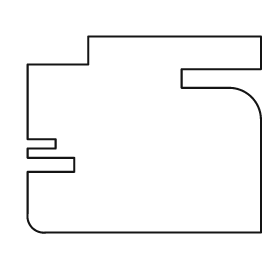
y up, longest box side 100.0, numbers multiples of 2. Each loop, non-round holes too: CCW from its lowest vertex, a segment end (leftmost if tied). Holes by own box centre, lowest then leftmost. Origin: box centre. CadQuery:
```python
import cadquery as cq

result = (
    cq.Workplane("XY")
    .moveTo(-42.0, -42.0)
    .lineTo(50.0, -42.0)
    .lineTo(50.0, 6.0)
    .threePointArc((46.0, 16.0), (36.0, 20.0))
    .lineTo(16.0, 20.0)
    .lineTo(16.0, 28.0)
    .lineTo(50.0, 28.0)
    .lineTo(50.0, 42.0)
    .lineTo(-24.0, 42.0)
    .lineTo(-24.0, 30.0)
    .lineTo(-50.0, 30.0)
    .lineTo(-50.0, -2.0)
    .lineTo(-38.0, -2.0)
    .lineTo(-38.0, -6.0)
    .lineTo(-50.0, -6.0)
    .lineTo(-50.0, -10.0)
    .lineTo(-30.0, -10.0)
    .lineTo(-30.0, -16.0)
    .lineTo(-50.0, -16.0)
    .lineTo(-50.0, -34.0)
    .threePointArc((-48.0, -40.0), (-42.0, -42.0))
    .close()
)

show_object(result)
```